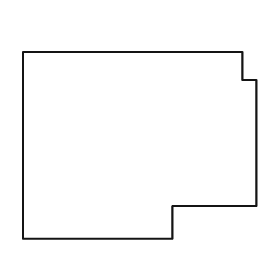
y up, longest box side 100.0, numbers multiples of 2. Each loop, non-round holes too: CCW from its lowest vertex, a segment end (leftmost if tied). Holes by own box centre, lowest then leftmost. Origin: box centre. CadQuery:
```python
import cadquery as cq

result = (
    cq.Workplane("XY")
    .moveTo(-50.0, -40.0)
    .lineTo(14.0, -40.0)
    .lineTo(14.0, -26.0)
    .lineTo(50.0, -26.0)
    .lineTo(50.0, 28.0)
    .lineTo(44.0, 28.0)
    .lineTo(44.0, 40.0)
    .lineTo(-50.0, 40.0)
    .close()
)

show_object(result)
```